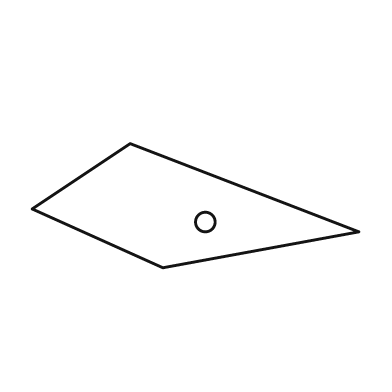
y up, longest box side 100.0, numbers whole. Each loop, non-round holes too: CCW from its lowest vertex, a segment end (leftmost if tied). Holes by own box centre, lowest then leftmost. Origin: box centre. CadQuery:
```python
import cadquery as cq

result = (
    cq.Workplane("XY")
    .moveTo(-10.0, -19.0)
    .lineTo(50.0, -8.0)
    .lineTo(-20.0, 19.0)
    .lineTo(-50.0, -1.0)
    .close()
    .moveTo(3.0, -5.0)
    .circle(3.0)
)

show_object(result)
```